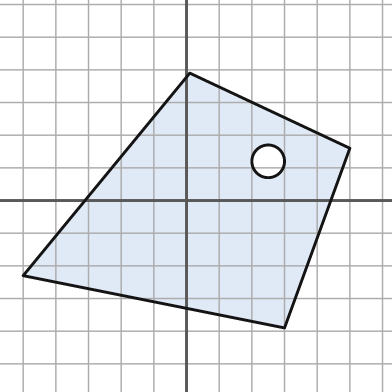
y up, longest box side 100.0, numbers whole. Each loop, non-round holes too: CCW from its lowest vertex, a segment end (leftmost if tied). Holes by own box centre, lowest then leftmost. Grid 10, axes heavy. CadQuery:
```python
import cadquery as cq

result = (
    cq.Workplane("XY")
    .moveTo(30.0, -39.0)
    .lineTo(50.0, 16.0)
    .lineTo(1.0, 39.0)
    .lineTo(-50.0, -23.0)
    .close()
    .moveTo(25.0, 12.0)
    .circle(5.0)
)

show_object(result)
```